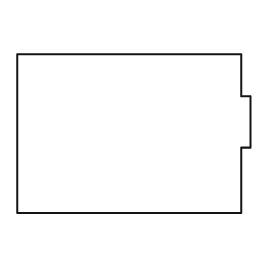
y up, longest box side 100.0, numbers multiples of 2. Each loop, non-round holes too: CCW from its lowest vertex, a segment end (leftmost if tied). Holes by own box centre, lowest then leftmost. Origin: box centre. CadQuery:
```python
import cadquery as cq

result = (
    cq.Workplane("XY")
    .moveTo(-50.0, -34.0)
    .lineTo(46.0, -34.0)
    .lineTo(46.0, -6.0)
    .lineTo(50.0, -6.0)
    .lineTo(50.0, 16.0)
    .lineTo(46.0, 16.0)
    .lineTo(46.0, 34.0)
    .lineTo(-50.0, 34.0)
    .close()
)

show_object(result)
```